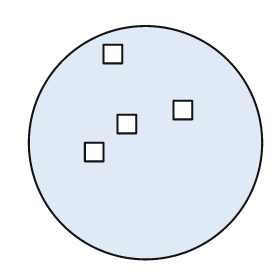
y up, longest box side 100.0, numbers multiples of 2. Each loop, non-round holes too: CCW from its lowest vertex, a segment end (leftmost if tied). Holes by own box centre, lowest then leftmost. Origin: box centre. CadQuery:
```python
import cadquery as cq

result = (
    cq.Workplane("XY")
    .moveTo(0.0, 0.0)
    .circle(50.0)
    .moveTo(-26.0, -8.0)
    .lineTo(-18.0, -8.0)
    .lineTo(-18.0, 0.0)
    .lineTo(-26.0, 0.0)
    .close()
    .moveTo(-12.0, 4.0)
    .lineTo(-4.0, 4.0)
    .lineTo(-4.0, 12.0)
    .lineTo(-12.0, 12.0)
    .close()
    .moveTo(12.0, 10.0)
    .lineTo(20.0, 10.0)
    .lineTo(20.0, 18.0)
    .lineTo(12.0, 18.0)
    .close()
    .moveTo(-18.0, 34.0)
    .lineTo(-10.0, 34.0)
    .lineTo(-10.0, 42.0)
    .lineTo(-18.0, 42.0)
    .close()
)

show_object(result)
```